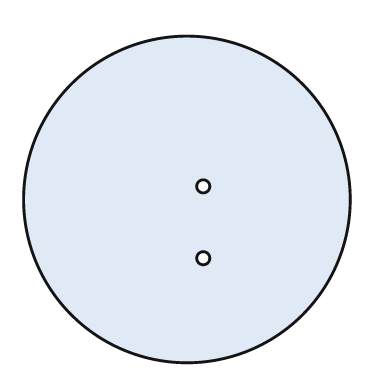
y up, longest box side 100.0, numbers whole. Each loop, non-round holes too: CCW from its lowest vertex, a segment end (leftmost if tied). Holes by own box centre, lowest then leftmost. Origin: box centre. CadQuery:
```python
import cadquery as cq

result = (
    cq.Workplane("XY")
    .moveTo(0.0, 0.0)
    .circle(50.0)
    .moveTo(5.0, -18.0)
    .circle(2.0)
    .moveTo(5.0, 4.0)
    .circle(2.0)
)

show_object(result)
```